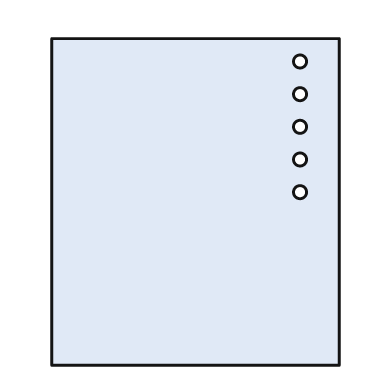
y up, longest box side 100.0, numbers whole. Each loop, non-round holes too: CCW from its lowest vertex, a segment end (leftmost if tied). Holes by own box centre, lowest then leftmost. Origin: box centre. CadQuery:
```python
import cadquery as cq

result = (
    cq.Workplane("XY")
    .moveTo(-44.0, -50.0)
    .lineTo(44.0, -50.0)
    .lineTo(44.0, 50.0)
    .lineTo(-44.0, 50.0)
    .close()
    .moveTo(32.0, 3.0)
    .circle(2.0)
    .moveTo(32.0, 13.0)
    .circle(2.0)
    .moveTo(32.0, 23.0)
    .circle(2.0)
    .moveTo(32.0, 33.0)
    .circle(2.0)
    .moveTo(32.0, 43.0)
    .circle(2.0)
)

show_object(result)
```